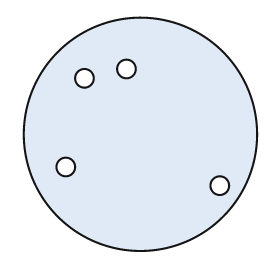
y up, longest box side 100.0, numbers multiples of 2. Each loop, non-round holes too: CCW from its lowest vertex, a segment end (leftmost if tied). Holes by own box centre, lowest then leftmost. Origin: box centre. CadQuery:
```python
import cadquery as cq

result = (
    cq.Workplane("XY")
    .moveTo(0.0, 0.0)
    .circle(50.0)
    .moveTo(34.0, -22.0)
    .circle(4.0)
    .moveTo(-32.0, -14.0)
    .circle(4.0)
    .moveTo(-24.0, 24.0)
    .circle(4.0)
    .moveTo(-6.0, 28.0)
    .circle(4.0)
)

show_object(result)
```